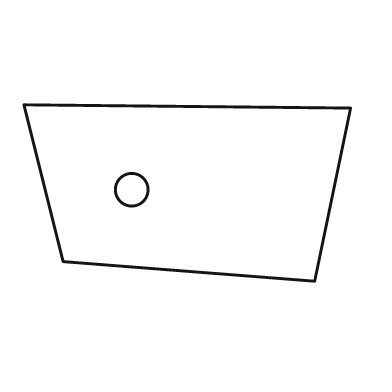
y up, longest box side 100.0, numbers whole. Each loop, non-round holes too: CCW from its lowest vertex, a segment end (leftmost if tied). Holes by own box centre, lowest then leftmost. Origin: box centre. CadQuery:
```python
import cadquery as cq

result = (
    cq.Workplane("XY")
    .moveTo(39.0, -27.0)
    .lineTo(50.0, 26.0)
    .lineTo(-50.0, 27.0)
    .lineTo(-38.0, -21.0)
    .close()
    .moveTo(-17.0, 1.0)
    .circle(5.0)
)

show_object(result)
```